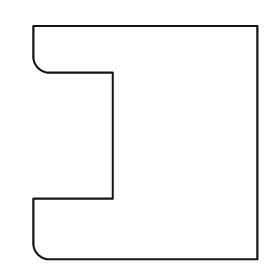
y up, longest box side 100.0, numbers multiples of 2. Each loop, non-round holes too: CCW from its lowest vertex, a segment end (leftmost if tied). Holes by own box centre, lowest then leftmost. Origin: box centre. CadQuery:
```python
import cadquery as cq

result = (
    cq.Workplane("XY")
    .moveTo(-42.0, -50.0)
    .lineTo(48.0, -50.0)
    .lineTo(48.0, 50.0)
    .lineTo(-48.0, 50.0)
    .lineTo(-48.0, 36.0)
    .threePointArc((-46.0, 32.0), (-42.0, 30.0))
    .lineTo(-14.0, 30.0)
    .lineTo(-14.0, -24.0)
    .lineTo(-48.0, -24.0)
    .lineTo(-48.0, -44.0)
    .threePointArc((-46.0, -48.0), (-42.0, -50.0))
    .close()
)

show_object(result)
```